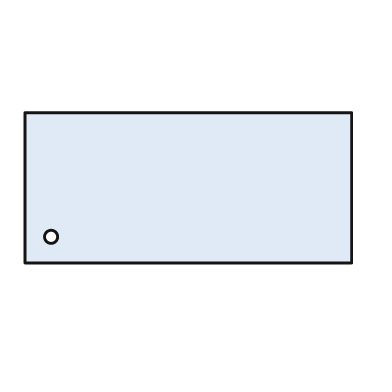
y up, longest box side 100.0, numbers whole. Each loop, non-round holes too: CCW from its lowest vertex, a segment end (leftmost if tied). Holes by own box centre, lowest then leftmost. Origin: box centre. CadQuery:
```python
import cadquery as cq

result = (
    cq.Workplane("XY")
    .moveTo(-50.0, -23.0)
    .lineTo(50.0, -23.0)
    .lineTo(50.0, 23.0)
    .lineTo(-50.0, 23.0)
    .close()
    .moveTo(-42.0, -15.0)
    .circle(2.0)
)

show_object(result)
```